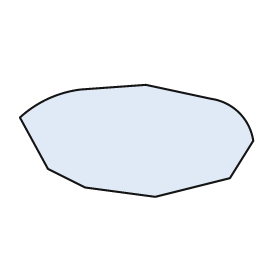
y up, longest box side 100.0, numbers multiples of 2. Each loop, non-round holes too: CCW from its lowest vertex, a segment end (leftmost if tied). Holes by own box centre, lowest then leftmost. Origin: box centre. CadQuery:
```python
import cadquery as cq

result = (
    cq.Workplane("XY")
    .moveTo(8.0, -24.0)
    .lineTo(40.0, -16.0)
    .lineTo(50.0, 0.0)
    .threePointArc((44.0, 12.0), (32.0, 18.0))
    .lineTo(4.0, 24.0)
    .lineTo(-24.0, 22.0)
    .threePointArc((-38.0, 18.0), (-50.0, 10.0))
    .lineTo(-38.0, -12.0)
    .lineTo(-22.0, -20.0)
    .close()
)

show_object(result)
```